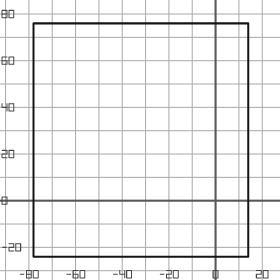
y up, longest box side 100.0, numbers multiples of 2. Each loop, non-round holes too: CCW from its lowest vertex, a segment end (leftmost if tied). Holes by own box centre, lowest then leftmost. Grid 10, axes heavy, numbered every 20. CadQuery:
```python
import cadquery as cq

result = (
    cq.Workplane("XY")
    .moveTo(-78.0, -24.0)
    .lineTo(14.0, -24.0)
    .lineTo(14.0, 76.0)
    .lineTo(-78.0, 76.0)
    .close()
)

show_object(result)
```